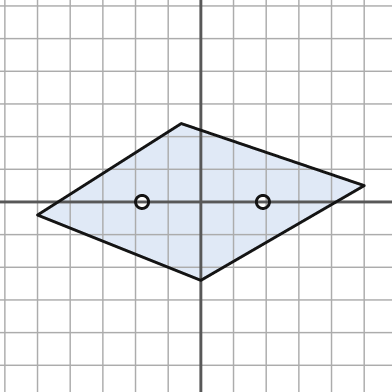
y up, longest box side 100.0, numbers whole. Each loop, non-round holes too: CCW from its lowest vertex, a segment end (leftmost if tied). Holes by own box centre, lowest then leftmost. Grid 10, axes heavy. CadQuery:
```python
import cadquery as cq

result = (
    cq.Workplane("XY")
    .moveTo(0.0, -24.0)
    .lineTo(50.0, 5.0)
    .lineTo(-6.0, 24.0)
    .lineTo(-50.0, -4.0)
    .close()
    .moveTo(-18.0, 0.0)
    .circle(2.0)
    .moveTo(19.0, 0.0)
    .circle(2.0)
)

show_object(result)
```